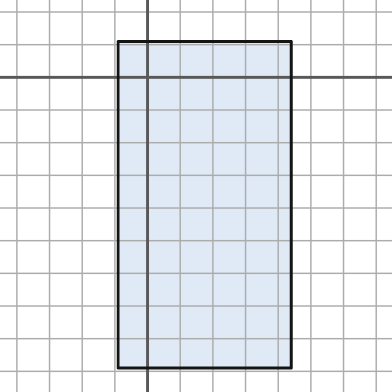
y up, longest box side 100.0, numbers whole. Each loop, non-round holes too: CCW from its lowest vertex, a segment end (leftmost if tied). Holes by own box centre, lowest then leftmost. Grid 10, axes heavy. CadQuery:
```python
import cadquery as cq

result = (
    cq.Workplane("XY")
    .moveTo(-9.0, -89.0)
    .lineTo(44.0, -89.0)
    .lineTo(44.0, 11.0)
    .lineTo(-9.0, 11.0)
    .close()
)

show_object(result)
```